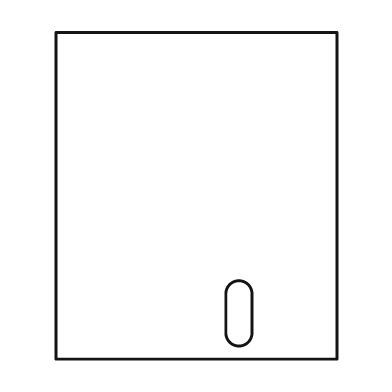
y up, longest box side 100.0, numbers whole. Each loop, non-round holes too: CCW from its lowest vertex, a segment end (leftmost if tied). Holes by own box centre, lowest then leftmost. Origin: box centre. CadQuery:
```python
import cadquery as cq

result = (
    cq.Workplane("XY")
    .moveTo(-43.0, -50.0)
    .lineTo(43.0, -50.0)
    .lineTo(43.0, 50.0)
    .lineTo(-43.0, 50.0)
    .close()
    .moveTo(9.0, -42.0)
    .threePointArc((13.0, -46.0), (17.0, -42.0))
    .lineTo(17.0, -30.0)
    .threePointArc((13.0, -26.0), (9.0, -30.0))
    .close()
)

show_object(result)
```